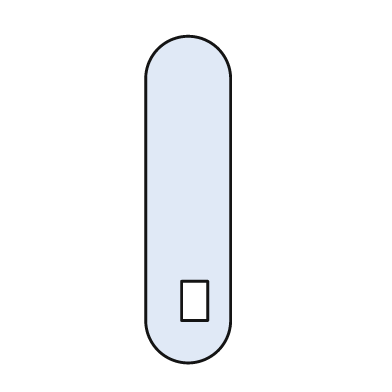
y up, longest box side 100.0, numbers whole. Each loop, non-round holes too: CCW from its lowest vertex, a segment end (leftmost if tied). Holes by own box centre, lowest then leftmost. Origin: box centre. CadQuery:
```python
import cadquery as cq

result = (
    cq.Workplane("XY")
    .moveTo(-13.0, -37.0)
    .threePointArc((0.0, -50.0), (13.0, -37.0))
    .lineTo(13.0, 37.0)
    .threePointArc((0.0, 50.0), (-13.0, 37.0))
    .close()
    .moveTo(-2.0, -37.0)
    .lineTo(6.0, -37.0)
    .lineTo(6.0, -25.0)
    .lineTo(-2.0, -25.0)
    .close()
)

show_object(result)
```